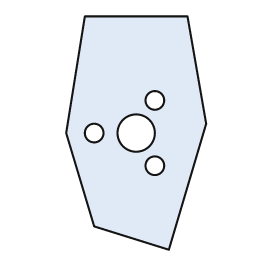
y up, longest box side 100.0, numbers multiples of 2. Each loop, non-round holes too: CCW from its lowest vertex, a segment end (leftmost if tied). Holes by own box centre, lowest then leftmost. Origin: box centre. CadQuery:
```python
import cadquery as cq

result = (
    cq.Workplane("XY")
    .moveTo(14.0, -50.0)
    .lineTo(30.0, 4.0)
    .lineTo(22.0, 50.0)
    .lineTo(-22.0, 50.0)
    .lineTo(-30.0, 0.0)
    .lineTo(-18.0, -40.0)
    .close()
    .moveTo(8.0, -14.0)
    .circle(4.0)
    .moveTo(-18.0, 0.0)
    .circle(4.0)
    .moveTo(0.0, 0.0)
    .circle(8.0)
    .moveTo(8.0, 14.0)
    .circle(4.0)
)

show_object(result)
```